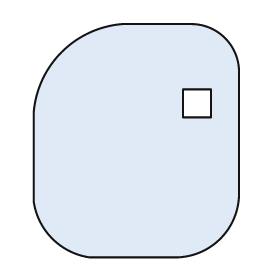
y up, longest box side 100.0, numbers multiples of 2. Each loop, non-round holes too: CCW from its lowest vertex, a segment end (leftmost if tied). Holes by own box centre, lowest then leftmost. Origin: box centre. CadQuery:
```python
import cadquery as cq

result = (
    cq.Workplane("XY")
    .moveTo(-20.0, -50.0)
    .lineTo(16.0, -50.0)
    .threePointArc((36.0, -42.0), (44.0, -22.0))
    .lineTo(44.0, 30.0)
    .threePointArc((38.0, 44.0), (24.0, 50.0))
    .lineTo(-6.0, 50.0)
    .threePointArc((-32.0, 38.0), (-44.0, 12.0))
    .lineTo(-44.0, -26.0)
    .threePointArc((-36.0, -42.0), (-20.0, -50.0))
    .close()
    .moveTo(20.0, 10.0)
    .lineTo(32.0, 10.0)
    .lineTo(32.0, 22.0)
    .lineTo(20.0, 22.0)
    .close()
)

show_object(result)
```